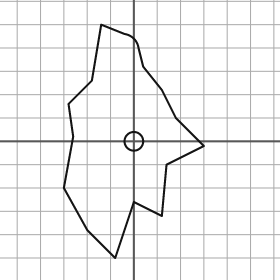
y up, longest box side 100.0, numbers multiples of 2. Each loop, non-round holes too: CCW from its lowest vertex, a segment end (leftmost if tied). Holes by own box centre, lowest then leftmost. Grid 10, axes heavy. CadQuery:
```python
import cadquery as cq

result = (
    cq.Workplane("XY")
    .moveTo(-8.0, -50.0)
    .lineTo(0.0, -26.0)
    .lineTo(12.0, -32.0)
    .lineTo(14.0, -10.0)
    .lineTo(30.0, -2.0)
    .lineTo(18.0, 10.0)
    .lineTo(12.0, 22.0)
    .lineTo(4.0, 32.0)
    .lineTo(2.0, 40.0)
    .threePointArc((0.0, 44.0), (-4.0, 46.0))
    .lineTo(-14.0, 50.0)
    .lineTo(-18.0, 26.0)
    .lineTo(-28.0, 16.0)
    .lineTo(-26.0, 2.0)
    .lineTo(-30.0, -20.0)
    .lineTo(-20.0, -38.0)
    .close()
    .moveTo(0.0, 0.0)
    .circle(4.0)
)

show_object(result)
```